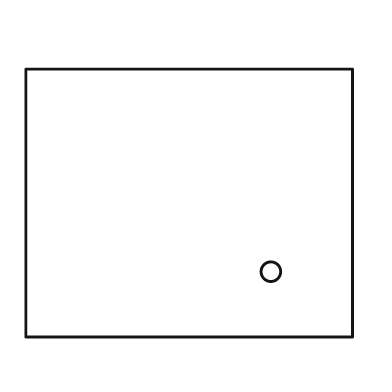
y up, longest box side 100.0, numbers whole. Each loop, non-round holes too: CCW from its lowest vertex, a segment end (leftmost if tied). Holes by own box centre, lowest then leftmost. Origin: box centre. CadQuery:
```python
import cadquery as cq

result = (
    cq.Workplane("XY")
    .moveTo(-50.0, -41.0)
    .lineTo(50.0, -41.0)
    .lineTo(50.0, 41.0)
    .lineTo(-50.0, 41.0)
    .close()
    .moveTo(25.0, -21.0)
    .circle(3.0)
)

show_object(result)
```